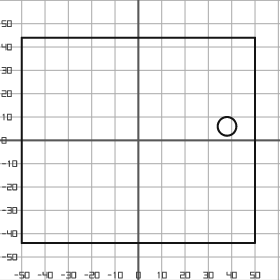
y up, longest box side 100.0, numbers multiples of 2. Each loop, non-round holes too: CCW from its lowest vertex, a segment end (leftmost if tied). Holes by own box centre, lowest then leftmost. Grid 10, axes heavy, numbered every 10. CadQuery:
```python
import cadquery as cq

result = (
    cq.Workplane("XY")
    .moveTo(-50.0, -44.0)
    .lineTo(50.0, -44.0)
    .lineTo(50.0, 44.0)
    .lineTo(-50.0, 44.0)
    .close()
    .moveTo(38.0, 6.0)
    .circle(4.0)
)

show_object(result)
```